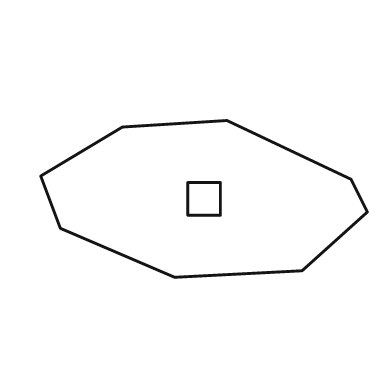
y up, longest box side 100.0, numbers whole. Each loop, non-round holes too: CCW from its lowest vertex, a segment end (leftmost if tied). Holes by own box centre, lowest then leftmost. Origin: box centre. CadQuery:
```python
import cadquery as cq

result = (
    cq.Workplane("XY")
    .moveTo(-9.0, -24.0)
    .lineTo(30.0, -22.0)
    .lineTo(50.0, -4.0)
    .lineTo(45.0, 6.0)
    .lineTo(7.0, 24.0)
    .lineTo(-25.0, 22.0)
    .lineTo(-50.0, 7.0)
    .lineTo(-44.0, -9.0)
    .close()
    .moveTo(-5.0, -5.0)
    .lineTo(5.0, -5.0)
    .lineTo(5.0, 5.0)
    .lineTo(-5.0, 5.0)
    .close()
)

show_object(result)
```